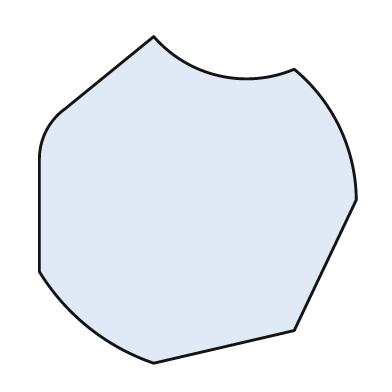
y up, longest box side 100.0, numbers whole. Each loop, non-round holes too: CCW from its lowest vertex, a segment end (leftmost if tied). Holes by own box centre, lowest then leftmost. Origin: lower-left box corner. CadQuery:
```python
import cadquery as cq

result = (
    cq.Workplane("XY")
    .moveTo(35.0, 0.0)
    .lineTo(78.0, 10.0)
    .lineTo(97.0, 50.0)
    .threePointArc((92.0, 72.0), (78.0, 90.0))
    .threePointArc((55.0, 88.0), (35.0, 100.0))
    .lineTo(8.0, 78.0)
    .threePointArc((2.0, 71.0), (0.0, 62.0))
    .lineTo(0.0, 28.0)
    .threePointArc((15.0, 11.0), (35.0, 0.0))
    .close()
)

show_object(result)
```